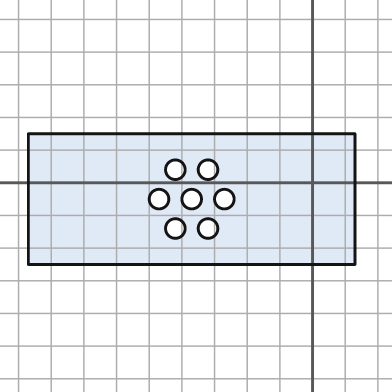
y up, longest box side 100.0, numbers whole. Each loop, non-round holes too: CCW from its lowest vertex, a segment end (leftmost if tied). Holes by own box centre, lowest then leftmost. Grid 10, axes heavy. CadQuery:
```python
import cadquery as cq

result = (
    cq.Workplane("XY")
    .moveTo(-87.0, -25.0)
    .lineTo(13.0, -25.0)
    .lineTo(13.0, 15.0)
    .lineTo(-87.0, 15.0)
    .close()
    .moveTo(-42.0, -14.0)
    .circle(3.0)
    .moveTo(-32.0, -14.0)
    .circle(3.0)
    .moveTo(-47.0, -5.0)
    .circle(3.0)
    .moveTo(-37.0, -5.0)
    .circle(3.0)
    .moveTo(-27.0, -5.0)
    .circle(3.0)
    .moveTo(-42.0, 4.0)
    .circle(3.0)
    .moveTo(-32.0, 4.0)
    .circle(3.0)
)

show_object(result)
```